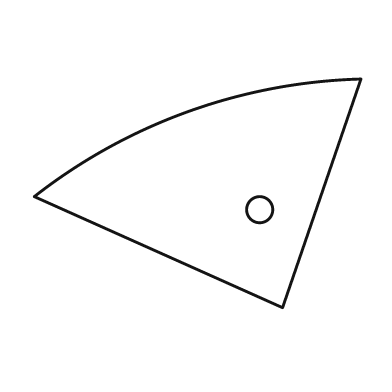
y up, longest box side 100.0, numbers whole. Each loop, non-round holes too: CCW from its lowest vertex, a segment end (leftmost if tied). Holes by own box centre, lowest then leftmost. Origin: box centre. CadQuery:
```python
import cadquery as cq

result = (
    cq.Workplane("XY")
    .moveTo(26.0, -35.0)
    .lineTo(50.0, 35.0)
    .threePointArc((-3.0, 25.0), (-50.0, -1.0))
    .close()
    .moveTo(19.0, -5.0)
    .circle(4.0)
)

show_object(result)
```